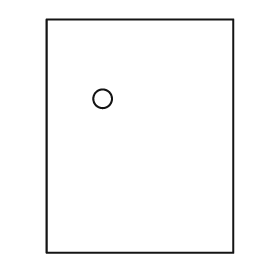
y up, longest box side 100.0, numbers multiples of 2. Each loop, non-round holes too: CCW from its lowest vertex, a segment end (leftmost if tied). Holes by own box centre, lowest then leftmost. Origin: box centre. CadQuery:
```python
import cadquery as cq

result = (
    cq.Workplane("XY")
    .moveTo(-40.0, -50.0)
    .lineTo(40.0, -50.0)
    .lineTo(40.0, 50.0)
    .lineTo(-40.0, 50.0)
    .close()
    .moveTo(-16.0, 16.0)
    .circle(4.0)
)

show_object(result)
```